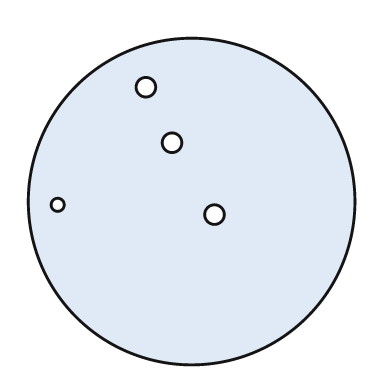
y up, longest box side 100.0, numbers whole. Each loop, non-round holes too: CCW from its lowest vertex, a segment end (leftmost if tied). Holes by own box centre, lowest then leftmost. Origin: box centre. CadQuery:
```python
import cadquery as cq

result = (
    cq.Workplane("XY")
    .moveTo(0.0, 0.0)
    .circle(50.0)
    .moveTo(7.0, -4.0)
    .circle(3.0)
    .moveTo(-41.0, -1.0)
    .circle(2.0)
    .moveTo(-6.0, 18.0)
    .circle(3.0)
    .moveTo(-14.0, 35.0)
    .circle(3.0)
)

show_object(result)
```